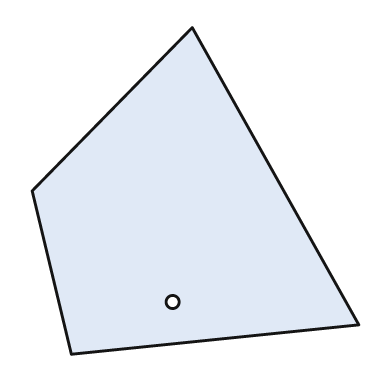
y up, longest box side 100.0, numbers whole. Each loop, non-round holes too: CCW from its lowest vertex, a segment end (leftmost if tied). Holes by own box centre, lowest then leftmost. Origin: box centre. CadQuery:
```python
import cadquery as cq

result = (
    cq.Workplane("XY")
    .moveTo(-38.0, -50.0)
    .lineTo(50.0, -41.0)
    .lineTo(-1.0, 50.0)
    .lineTo(-50.0, 0.0)
    .close()
    .moveTo(-7.0, -34.0)
    .circle(2.0)
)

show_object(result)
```